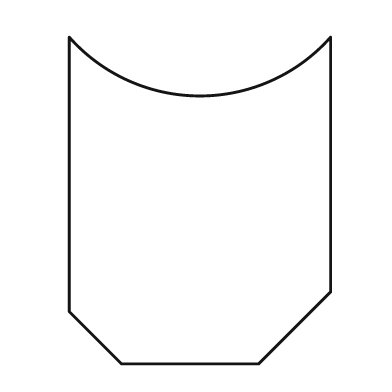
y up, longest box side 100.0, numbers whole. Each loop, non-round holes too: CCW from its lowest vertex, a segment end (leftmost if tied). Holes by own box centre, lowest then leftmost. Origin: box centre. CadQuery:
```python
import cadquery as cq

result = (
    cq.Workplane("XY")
    .moveTo(-24.0, -50.0)
    .lineTo(18.0, -50.0)
    .lineTo(40.0, -28.0)
    .lineTo(40.0, 50.0)
    .threePointArc((0.0, 32.0), (-40.0, 50.0))
    .lineTo(-40.0, -34.0)
    .close()
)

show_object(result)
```